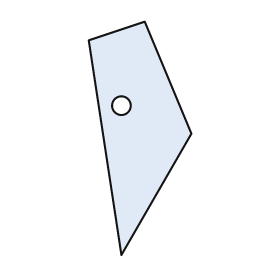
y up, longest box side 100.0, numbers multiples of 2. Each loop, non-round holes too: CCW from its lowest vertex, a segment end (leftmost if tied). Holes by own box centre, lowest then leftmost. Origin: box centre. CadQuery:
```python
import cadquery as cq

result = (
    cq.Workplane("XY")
    .moveTo(-8.0, -50.0)
    .lineTo(22.0, 2.0)
    .lineTo(2.0, 50.0)
    .lineTo(-22.0, 42.0)
    .close()
    .moveTo(-8.0, 14.0)
    .circle(4.0)
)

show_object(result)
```